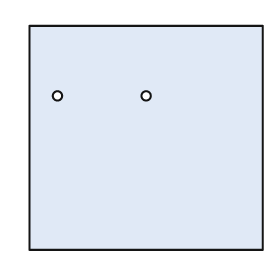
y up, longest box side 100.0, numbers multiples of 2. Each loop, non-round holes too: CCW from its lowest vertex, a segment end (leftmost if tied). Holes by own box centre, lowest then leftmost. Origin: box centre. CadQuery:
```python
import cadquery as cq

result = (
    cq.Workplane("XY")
    .moveTo(-50.0, -48.0)
    .lineTo(50.0, -48.0)
    .lineTo(50.0, 48.0)
    .lineTo(-50.0, 48.0)
    .close()
    .moveTo(-38.0, 18.0)
    .circle(2.0)
    .moveTo(0.0, 18.0)
    .circle(2.0)
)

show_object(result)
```